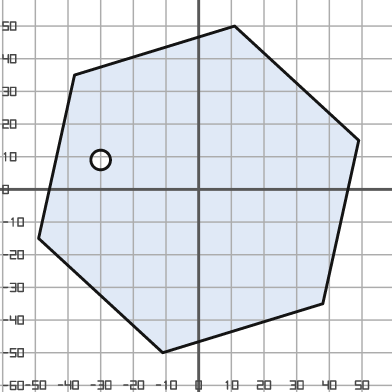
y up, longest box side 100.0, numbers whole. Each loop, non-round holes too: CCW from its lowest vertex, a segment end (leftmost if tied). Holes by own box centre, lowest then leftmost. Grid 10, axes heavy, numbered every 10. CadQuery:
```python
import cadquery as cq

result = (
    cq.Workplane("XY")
    .moveTo(-11.0, -50.0)
    .lineTo(38.0, -35.0)
    .lineTo(49.0, 15.0)
    .lineTo(11.0, 50.0)
    .lineTo(-38.0, 35.0)
    .lineTo(-49.0, -15.0)
    .close()
    .moveTo(-30.0, 9.0)
    .circle(3.0)
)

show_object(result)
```